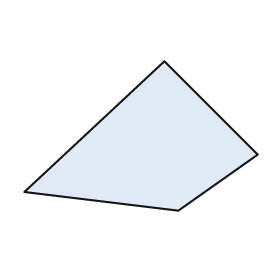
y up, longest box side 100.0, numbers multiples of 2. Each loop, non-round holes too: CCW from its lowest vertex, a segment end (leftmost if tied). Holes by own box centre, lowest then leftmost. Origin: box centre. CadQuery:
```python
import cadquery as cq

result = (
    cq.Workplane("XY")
    .moveTo(16.0, -32.0)
    .lineTo(50.0, -8.0)
    .lineTo(10.0, 32.0)
    .lineTo(-50.0, -24.0)
    .close()
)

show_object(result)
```